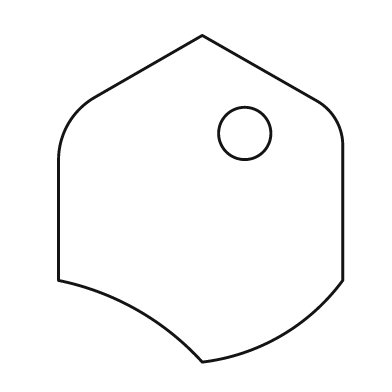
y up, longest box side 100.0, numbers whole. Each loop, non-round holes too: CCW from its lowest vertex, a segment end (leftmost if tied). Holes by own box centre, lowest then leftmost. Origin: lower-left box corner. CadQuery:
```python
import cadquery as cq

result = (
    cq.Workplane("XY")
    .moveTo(44.0, 0.0)
    .threePointArc((68.0, 8.0), (87.0, 25.0))
    .lineTo(87.0, 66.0)
    .threePointArc((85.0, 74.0), (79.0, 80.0))
    .lineTo(44.0, 100.0)
    .lineTo(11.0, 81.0)
    .threePointArc((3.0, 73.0), (0.0, 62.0))
    .lineTo(0.0, 25.0)
    .threePointArc((24.0, 16.0), (44.0, 0.0))
    .close()
    .moveTo(57.0, 70.0)
    .circle(8.0)
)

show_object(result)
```